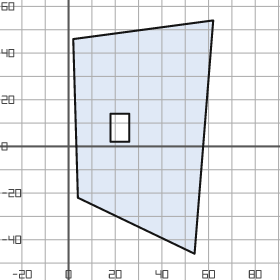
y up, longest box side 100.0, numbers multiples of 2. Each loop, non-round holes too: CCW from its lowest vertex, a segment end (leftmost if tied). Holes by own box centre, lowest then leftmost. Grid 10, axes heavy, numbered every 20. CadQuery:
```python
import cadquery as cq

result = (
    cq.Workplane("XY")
    .moveTo(54.0, -46.0)
    .lineTo(62.0, 54.0)
    .lineTo(2.0, 46.0)
    .lineTo(4.0, -22.0)
    .close()
    .moveTo(18.0, 2.0)
    .lineTo(26.0, 2.0)
    .lineTo(26.0, 14.0)
    .lineTo(18.0, 14.0)
    .close()
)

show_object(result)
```